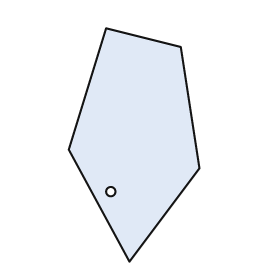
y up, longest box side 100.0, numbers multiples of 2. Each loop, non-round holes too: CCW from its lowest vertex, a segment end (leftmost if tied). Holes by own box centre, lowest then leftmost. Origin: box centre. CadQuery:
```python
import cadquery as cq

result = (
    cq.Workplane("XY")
    .moveTo(-2.0, -50.0)
    .lineTo(28.0, -10.0)
    .lineTo(20.0, 42.0)
    .lineTo(-12.0, 50.0)
    .lineTo(-28.0, -2.0)
    .close()
    .moveTo(-10.0, -20.0)
    .circle(2.0)
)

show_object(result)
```